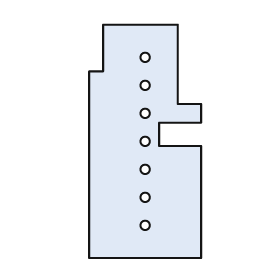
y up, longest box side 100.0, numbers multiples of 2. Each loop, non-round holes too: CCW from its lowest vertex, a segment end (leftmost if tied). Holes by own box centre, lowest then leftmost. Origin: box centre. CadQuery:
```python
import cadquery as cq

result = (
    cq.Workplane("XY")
    .moveTo(-24.0, -50.0)
    .lineTo(24.0, -50.0)
    .lineTo(24.0, -2.0)
    .lineTo(6.0, -2.0)
    .lineTo(6.0, 8.0)
    .lineTo(24.0, 8.0)
    .lineTo(24.0, 16.0)
    .lineTo(14.0, 16.0)
    .lineTo(14.0, 50.0)
    .lineTo(-18.0, 50.0)
    .lineTo(-18.0, 30.0)
    .lineTo(-24.0, 30.0)
    .close()
    .moveTo(0.0, -36.0)
    .circle(2.0)
    .moveTo(0.0, -24.0)
    .circle(2.0)
    .moveTo(0.0, -12.0)
    .circle(2.0)
    .moveTo(0.0, 0.0)
    .circle(2.0)
    .moveTo(0.0, 12.0)
    .circle(2.0)
    .moveTo(0.0, 24.0)
    .circle(2.0)
    .moveTo(0.0, 36.0)
    .circle(2.0)
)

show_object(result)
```